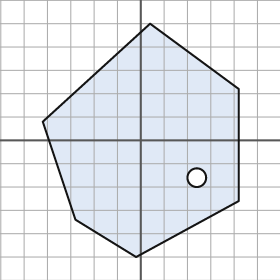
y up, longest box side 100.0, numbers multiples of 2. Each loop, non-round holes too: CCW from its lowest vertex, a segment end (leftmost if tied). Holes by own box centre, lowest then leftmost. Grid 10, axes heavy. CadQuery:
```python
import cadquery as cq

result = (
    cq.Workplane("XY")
    .moveTo(-2.0, -50.0)
    .lineTo(42.0, -26.0)
    .lineTo(42.0, 22.0)
    .lineTo(4.0, 50.0)
    .lineTo(-42.0, 8.0)
    .lineTo(-28.0, -34.0)
    .close()
    .moveTo(24.0, -16.0)
    .circle(4.0)
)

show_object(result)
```